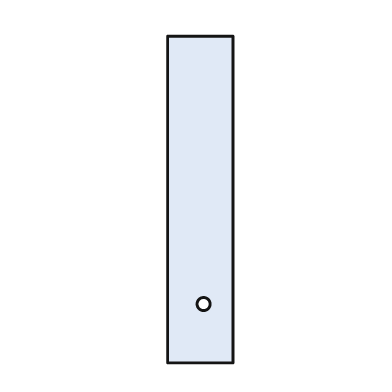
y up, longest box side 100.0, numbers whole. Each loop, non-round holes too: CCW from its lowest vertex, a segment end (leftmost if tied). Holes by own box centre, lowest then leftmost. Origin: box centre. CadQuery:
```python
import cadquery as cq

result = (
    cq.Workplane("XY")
    .moveTo(-10.0, -50.0)
    .lineTo(10.0, -50.0)
    .lineTo(10.0, 50.0)
    .lineTo(-10.0, 50.0)
    .close()
    .moveTo(1.0, -32.0)
    .circle(2.0)
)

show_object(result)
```